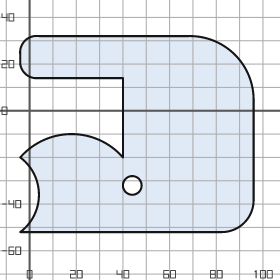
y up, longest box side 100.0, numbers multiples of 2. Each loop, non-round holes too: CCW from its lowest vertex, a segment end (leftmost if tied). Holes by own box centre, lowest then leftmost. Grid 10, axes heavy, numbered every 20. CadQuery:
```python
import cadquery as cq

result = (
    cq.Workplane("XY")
    .moveTo(-4.0, -52.0)
    .lineTo(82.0, -52.0)
    .threePointArc((92.0, -48.0), (96.0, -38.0))
    .lineTo(96.0, 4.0)
    .threePointArc((88.0, 24.0), (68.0, 32.0))
    .lineTo(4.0, 32.0)
    .threePointArc((-2.0, 30.0), (-4.0, 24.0))
    .lineTo(-4.0, 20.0)
    .threePointArc((-2.0, 16.0), (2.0, 14.0))
    .lineTo(40.0, 14.0)
    .lineTo(40.0, -20.0)
    .threePointArc((18.0, -10.0), (-4.0, -20.0))
    .threePointArc((4.0, -36.0), (-4.0, -52.0))
    .close()
    .moveTo(44.0, -32.0)
    .circle(4.0)
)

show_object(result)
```